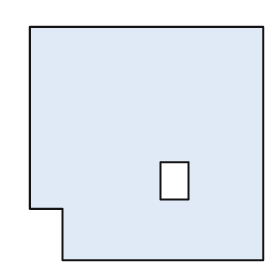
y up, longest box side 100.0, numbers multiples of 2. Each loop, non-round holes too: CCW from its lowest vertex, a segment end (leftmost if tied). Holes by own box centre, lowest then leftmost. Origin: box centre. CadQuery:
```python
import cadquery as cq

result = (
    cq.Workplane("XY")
    .moveTo(-36.0, -50.0)
    .lineTo(50.0, -50.0)
    .lineTo(50.0, 50.0)
    .lineTo(-50.0, 50.0)
    .lineTo(-50.0, -28.0)
    .lineTo(-36.0, -28.0)
    .close()
    .moveTo(6.0, -24.0)
    .lineTo(18.0, -24.0)
    .lineTo(18.0, -8.0)
    .lineTo(6.0, -8.0)
    .close()
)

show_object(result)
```